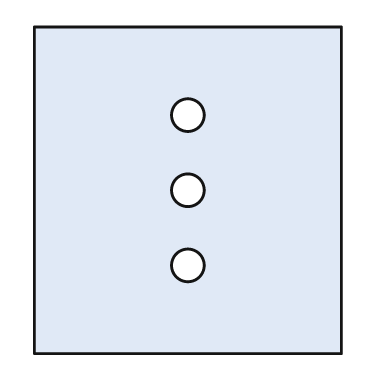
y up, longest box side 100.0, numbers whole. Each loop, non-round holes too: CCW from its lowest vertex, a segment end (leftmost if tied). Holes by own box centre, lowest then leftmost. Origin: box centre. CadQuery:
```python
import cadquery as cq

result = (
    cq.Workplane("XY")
    .moveTo(-47.0, -50.0)
    .lineTo(47.0, -50.0)
    .lineTo(47.0, 50.0)
    .lineTo(-47.0, 50.0)
    .close()
    .moveTo(0.0, -23.0)
    .circle(5.0)
    .moveTo(0.0, 0.0)
    .circle(5.0)
    .moveTo(0.0, 23.0)
    .circle(5.0)
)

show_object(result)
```